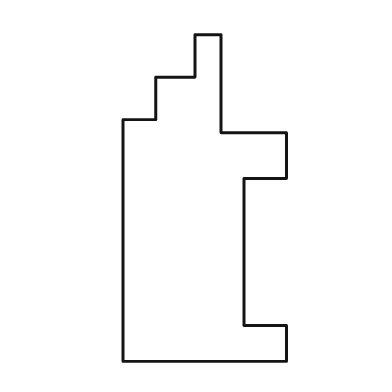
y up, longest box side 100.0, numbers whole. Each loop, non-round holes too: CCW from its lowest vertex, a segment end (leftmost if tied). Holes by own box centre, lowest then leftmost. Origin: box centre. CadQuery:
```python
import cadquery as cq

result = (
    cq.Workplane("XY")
    .moveTo(-25.0, -50.0)
    .lineTo(25.0, -50.0)
    .lineTo(25.0, -39.0)
    .lineTo(12.0, -39.0)
    .lineTo(12.0, 6.0)
    .lineTo(25.0, 6.0)
    .lineTo(25.0, 20.0)
    .lineTo(5.0, 20.0)
    .lineTo(5.0, 50.0)
    .lineTo(-3.0, 50.0)
    .lineTo(-3.0, 37.0)
    .lineTo(-15.0, 37.0)
    .lineTo(-15.0, 24.0)
    .lineTo(-25.0, 24.0)
    .close()
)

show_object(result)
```